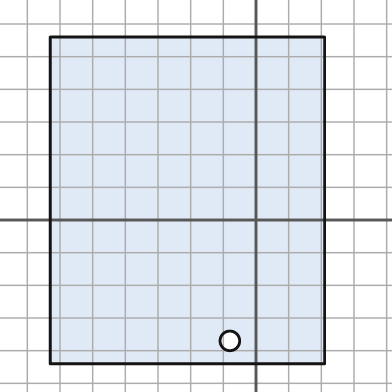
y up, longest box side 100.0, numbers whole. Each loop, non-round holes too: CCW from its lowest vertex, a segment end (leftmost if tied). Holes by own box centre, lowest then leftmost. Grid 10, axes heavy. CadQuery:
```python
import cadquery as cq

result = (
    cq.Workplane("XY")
    .moveTo(-63.0, -44.0)
    .lineTo(21.0, -44.0)
    .lineTo(21.0, 56.0)
    .lineTo(-63.0, 56.0)
    .close()
    .moveTo(-8.0, -37.0)
    .circle(3.0)
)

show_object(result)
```